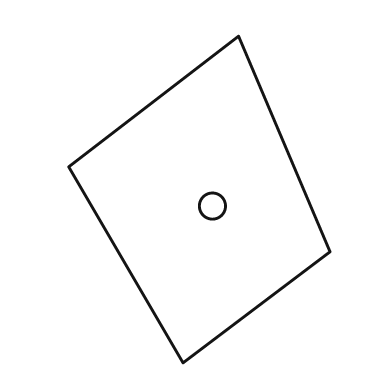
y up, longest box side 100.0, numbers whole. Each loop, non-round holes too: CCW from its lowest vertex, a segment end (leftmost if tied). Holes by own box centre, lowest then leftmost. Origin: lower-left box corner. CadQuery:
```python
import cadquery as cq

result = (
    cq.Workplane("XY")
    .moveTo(35.0, 0.0)
    .lineTo(80.0, 34.0)
    .lineTo(52.0, 100.0)
    .lineTo(0.0, 60.0)
    .close()
    .moveTo(44.0, 48.0)
    .circle(4.0)
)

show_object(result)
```